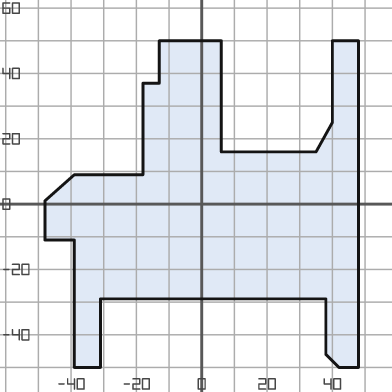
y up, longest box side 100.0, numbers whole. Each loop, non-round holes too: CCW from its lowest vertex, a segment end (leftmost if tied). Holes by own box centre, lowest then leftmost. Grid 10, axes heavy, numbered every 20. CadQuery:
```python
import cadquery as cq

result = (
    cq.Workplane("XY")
    .moveTo(-39.0, -50.0)
    .lineTo(-31.0, -50.0)
    .lineTo(-31.0, -29.0)
    .lineTo(38.0, -29.0)
    .lineTo(38.0, -46.0)
    .lineTo(42.0, -50.0)
    .lineTo(48.0, -50.0)
    .lineTo(48.0, 50.0)
    .lineTo(40.0, 50.0)
    .lineTo(40.0, 25.0)
    .lineTo(35.0, 16.0)
    .lineTo(6.0, 16.0)
    .lineTo(6.0, 50.0)
    .lineTo(-13.0, 50.0)
    .lineTo(-13.0, 37.0)
    .lineTo(-18.0, 37.0)
    .lineTo(-18.0, 9.0)
    .lineTo(-39.0, 9.0)
    .lineTo(-48.0, 1.0)
    .lineTo(-48.0, -11.0)
    .lineTo(-39.0, -11.0)
    .close()
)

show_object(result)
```